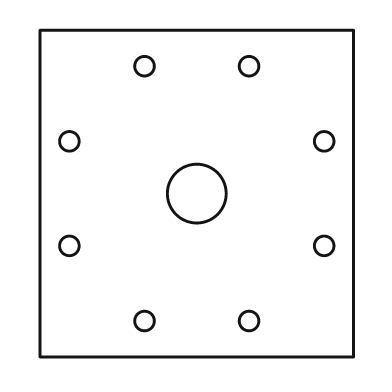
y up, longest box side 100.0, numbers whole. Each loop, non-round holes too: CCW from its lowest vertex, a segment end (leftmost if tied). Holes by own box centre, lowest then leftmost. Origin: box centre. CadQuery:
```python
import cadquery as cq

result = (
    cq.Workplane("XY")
    .moveTo(-48.0, -50.0)
    .lineTo(48.0, -50.0)
    .lineTo(48.0, 50.0)
    .lineTo(-48.0, 50.0)
    .close()
    .moveTo(-16.0, -39.0)
    .circle(3.0)
    .moveTo(16.0, -39.0)
    .circle(3.0)
    .moveTo(-39.0, -16.0)
    .circle(3.0)
    .moveTo(39.0, -16.0)
    .circle(3.0)
    .moveTo(0.0, 0.0)
    .circle(9.0)
    .moveTo(-39.0, 16.0)
    .circle(3.0)
    .moveTo(39.0, 16.0)
    .circle(3.0)
    .moveTo(-16.0, 39.0)
    .circle(3.0)
    .moveTo(16.0, 39.0)
    .circle(3.0)
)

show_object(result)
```